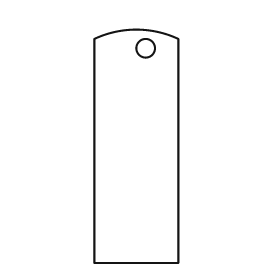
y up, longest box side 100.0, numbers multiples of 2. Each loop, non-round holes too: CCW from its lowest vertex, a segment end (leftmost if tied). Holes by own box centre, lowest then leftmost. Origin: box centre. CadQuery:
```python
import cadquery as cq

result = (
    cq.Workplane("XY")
    .moveTo(-18.0, -50.0)
    .lineTo(18.0, -50.0)
    .lineTo(18.0, 46.0)
    .threePointArc((0.0, 50.0), (-18.0, 46.0))
    .close()
    .moveTo(4.0, 42.0)
    .circle(4.0)
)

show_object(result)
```